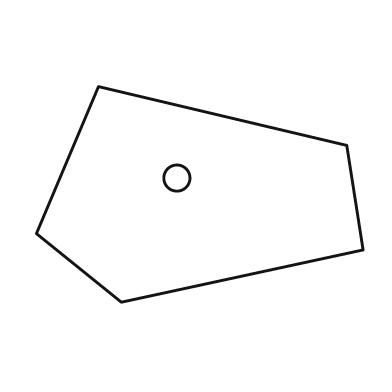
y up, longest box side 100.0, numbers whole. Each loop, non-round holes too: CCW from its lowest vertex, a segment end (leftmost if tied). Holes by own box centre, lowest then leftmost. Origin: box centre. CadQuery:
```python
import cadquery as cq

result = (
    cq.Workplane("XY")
    .moveTo(-24.0, -33.0)
    .lineTo(50.0, -17.0)
    .lineTo(45.0, 15.0)
    .lineTo(-31.0, 33.0)
    .lineTo(-50.0, -12.0)
    .close()
    .moveTo(-7.0, 5.0)
    .circle(4.0)
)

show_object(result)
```